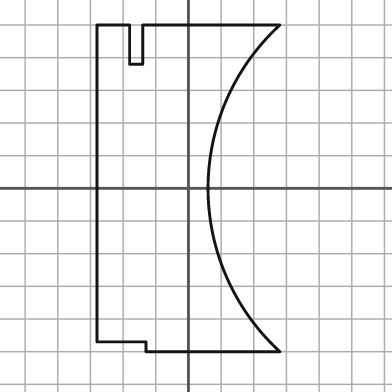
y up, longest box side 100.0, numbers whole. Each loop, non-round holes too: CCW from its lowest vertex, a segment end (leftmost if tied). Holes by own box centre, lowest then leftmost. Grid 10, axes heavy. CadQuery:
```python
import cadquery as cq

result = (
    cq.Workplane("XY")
    .moveTo(-13.0, -50.0)
    .lineTo(28.0, -50.0)
    .threePointArc((6.0, 0.0), (28.0, 50.0))
    .lineTo(-14.0, 50.0)
    .lineTo(-14.0, 38.0)
    .lineTo(-18.0, 38.0)
    .lineTo(-18.0, 50.0)
    .lineTo(-28.0, 50.0)
    .lineTo(-28.0, -47.0)
    .lineTo(-13.0, -47.0)
    .close()
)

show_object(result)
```